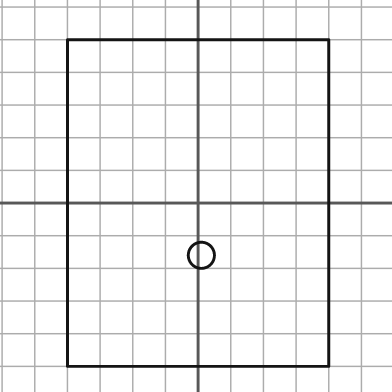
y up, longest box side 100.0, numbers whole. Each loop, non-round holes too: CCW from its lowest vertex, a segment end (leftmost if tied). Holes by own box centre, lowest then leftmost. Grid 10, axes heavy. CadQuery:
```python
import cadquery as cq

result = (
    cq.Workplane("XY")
    .moveTo(-40.0, -50.0)
    .lineTo(40.0, -50.0)
    .lineTo(40.0, 50.0)
    .lineTo(-40.0, 50.0)
    .close()
    .moveTo(1.0, -16.0)
    .circle(4.0)
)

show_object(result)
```